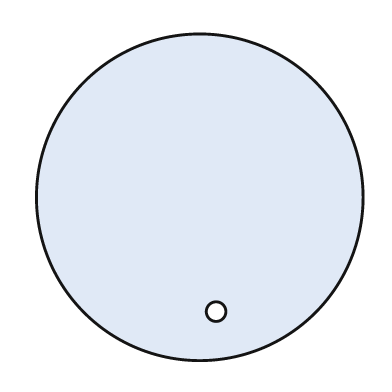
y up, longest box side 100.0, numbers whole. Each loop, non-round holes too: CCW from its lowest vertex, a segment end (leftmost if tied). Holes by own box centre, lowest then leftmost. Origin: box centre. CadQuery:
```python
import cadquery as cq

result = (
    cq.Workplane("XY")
    .moveTo(0.0, 0.0)
    .circle(50.0)
    .moveTo(5.0, -35.0)
    .circle(3.0)
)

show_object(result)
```